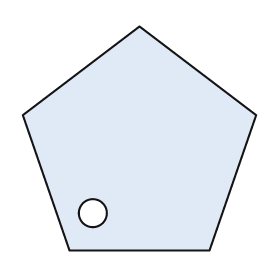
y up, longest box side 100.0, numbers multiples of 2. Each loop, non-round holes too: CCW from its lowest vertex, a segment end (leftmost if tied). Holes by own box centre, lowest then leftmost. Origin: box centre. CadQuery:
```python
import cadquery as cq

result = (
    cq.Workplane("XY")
    .moveTo(-30.0, -48.0)
    .lineTo(30.0, -48.0)
    .lineTo(50.0, 10.0)
    .lineTo(0.0, 48.0)
    .lineTo(-50.0, 10.0)
    .close()
    .moveTo(-20.0, -32.0)
    .circle(6.0)
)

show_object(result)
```